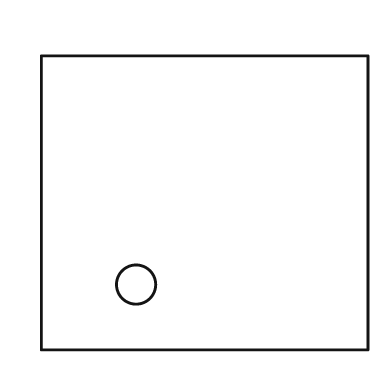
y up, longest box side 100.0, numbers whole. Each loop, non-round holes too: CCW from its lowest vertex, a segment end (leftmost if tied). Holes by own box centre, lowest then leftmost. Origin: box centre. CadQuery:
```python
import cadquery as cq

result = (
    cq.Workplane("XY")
    .moveTo(-50.0, -45.0)
    .lineTo(50.0, -45.0)
    .lineTo(50.0, 45.0)
    .lineTo(-50.0, 45.0)
    .close()
    .moveTo(-21.0, -25.0)
    .circle(6.0)
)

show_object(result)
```